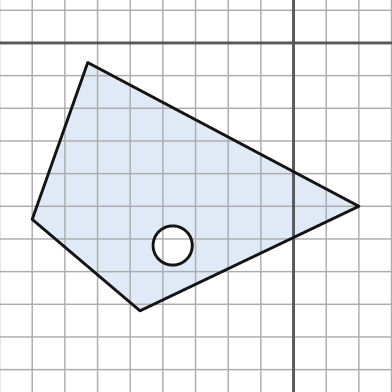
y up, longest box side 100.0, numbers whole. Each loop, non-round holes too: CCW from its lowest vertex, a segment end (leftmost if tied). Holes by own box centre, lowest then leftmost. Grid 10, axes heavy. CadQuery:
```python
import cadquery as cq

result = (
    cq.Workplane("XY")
    .moveTo(-47.0, -82.0)
    .lineTo(20.0, -50.0)
    .lineTo(-63.0, -6.0)
    .lineTo(-80.0, -54.0)
    .close()
    .moveTo(-37.0, -62.0)
    .circle(6.0)
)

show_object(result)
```